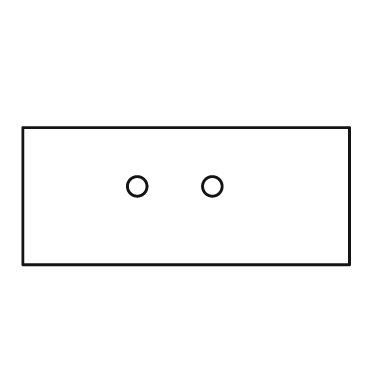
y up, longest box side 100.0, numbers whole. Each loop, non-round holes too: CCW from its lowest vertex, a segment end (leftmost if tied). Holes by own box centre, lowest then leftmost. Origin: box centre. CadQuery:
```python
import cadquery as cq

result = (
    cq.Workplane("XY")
    .moveTo(-50.0, -21.0)
    .lineTo(50.0, -21.0)
    .lineTo(50.0, 21.0)
    .lineTo(-50.0, 21.0)
    .close()
    .moveTo(-15.0, 3.0)
    .circle(3.0)
    .moveTo(8.0, 3.0)
    .circle(3.0)
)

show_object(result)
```